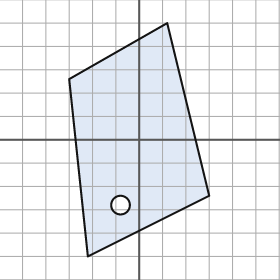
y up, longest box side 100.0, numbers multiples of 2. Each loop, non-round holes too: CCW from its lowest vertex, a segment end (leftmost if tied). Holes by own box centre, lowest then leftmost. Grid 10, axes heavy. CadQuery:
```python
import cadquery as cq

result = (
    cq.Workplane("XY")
    .moveTo(-22.0, -50.0)
    .lineTo(30.0, -24.0)
    .lineTo(12.0, 50.0)
    .lineTo(-30.0, 26.0)
    .close()
    .moveTo(-8.0, -28.0)
    .circle(4.0)
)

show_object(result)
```